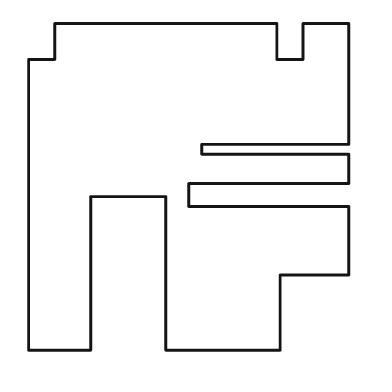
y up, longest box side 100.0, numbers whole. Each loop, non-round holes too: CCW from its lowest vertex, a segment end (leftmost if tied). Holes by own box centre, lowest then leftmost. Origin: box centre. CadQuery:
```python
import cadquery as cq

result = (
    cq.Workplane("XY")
    .moveTo(-49.0, -50.0)
    .lineTo(-30.0, -50.0)
    .lineTo(-30.0, -3.0)
    .lineTo(-7.0, -3.0)
    .lineTo(-7.0, -50.0)
    .lineTo(28.0, -50.0)
    .lineTo(28.0, -27.0)
    .lineTo(49.0, -27.0)
    .lineTo(49.0, -6.0)
    .lineTo(0.0, -6.0)
    .lineTo(0.0, 1.0)
    .lineTo(49.0, 1.0)
    .lineTo(49.0, 10.0)
    .lineTo(4.0, 10.0)
    .lineTo(4.0, 13.0)
    .lineTo(49.0, 13.0)
    .lineTo(49.0, 50.0)
    .lineTo(35.0, 50.0)
    .lineTo(35.0, 39.0)
    .lineTo(27.0, 39.0)
    .lineTo(27.0, 50.0)
    .lineTo(-41.0, 50.0)
    .lineTo(-41.0, 39.0)
    .lineTo(-49.0, 39.0)
    .close()
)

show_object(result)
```